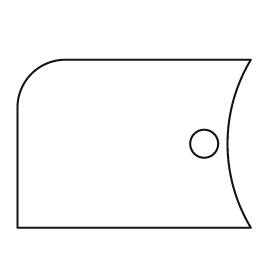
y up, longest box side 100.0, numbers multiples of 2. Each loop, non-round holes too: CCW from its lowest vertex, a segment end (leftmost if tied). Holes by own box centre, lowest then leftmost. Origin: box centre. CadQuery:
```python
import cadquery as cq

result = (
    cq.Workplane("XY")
    .moveTo(-50.0, -36.0)
    .lineTo(50.0, -36.0)
    .threePointArc((40.0, 0.0), (50.0, 36.0))
    .lineTo(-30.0, 36.0)
    .threePointArc((-44.0, 30.0), (-50.0, 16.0))
    .close()
    .moveTo(30.0, 0.0)
    .circle(6.0)
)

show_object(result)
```